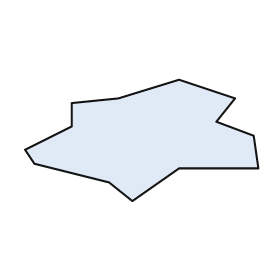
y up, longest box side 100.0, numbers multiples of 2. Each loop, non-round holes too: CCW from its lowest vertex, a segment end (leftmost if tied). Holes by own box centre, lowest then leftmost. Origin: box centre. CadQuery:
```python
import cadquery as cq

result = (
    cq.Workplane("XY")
    .moveTo(-4.0, -26.0)
    .lineTo(16.0, -12.0)
    .lineTo(50.0, -12.0)
    .lineTo(48.0, 2.0)
    .lineTo(32.0, 8.0)
    .lineTo(40.0, 18.0)
    .lineTo(16.0, 26.0)
    .lineTo(-10.0, 18.0)
    .lineTo(-30.0, 16.0)
    .lineTo(-30.0, 6.0)
    .lineTo(-50.0, -4.0)
    .lineTo(-46.0, -10.0)
    .lineTo(-14.0, -18.0)
    .close()
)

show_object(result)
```